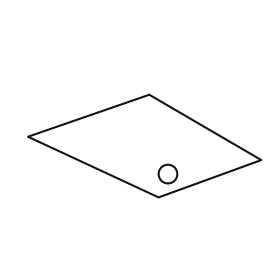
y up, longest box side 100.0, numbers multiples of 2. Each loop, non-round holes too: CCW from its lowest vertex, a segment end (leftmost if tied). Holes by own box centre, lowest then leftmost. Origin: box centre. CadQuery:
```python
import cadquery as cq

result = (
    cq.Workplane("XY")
    .moveTo(6.0, -22.0)
    .lineTo(50.0, -6.0)
    .lineTo(2.0, 22.0)
    .lineTo(-50.0, 4.0)
    .close()
    .moveTo(10.0, -12.0)
    .circle(4.0)
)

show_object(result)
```